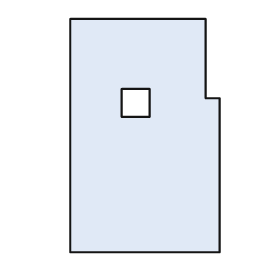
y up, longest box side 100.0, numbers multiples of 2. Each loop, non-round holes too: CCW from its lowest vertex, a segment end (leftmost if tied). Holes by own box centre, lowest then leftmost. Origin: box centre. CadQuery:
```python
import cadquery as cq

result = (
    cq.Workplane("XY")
    .moveTo(-32.0, -50.0)
    .lineTo(32.0, -50.0)
    .lineTo(32.0, 16.0)
    .lineTo(26.0, 16.0)
    .lineTo(26.0, 50.0)
    .lineTo(-32.0, 50.0)
    .close()
    .moveTo(-10.0, 8.0)
    .lineTo(2.0, 8.0)
    .lineTo(2.0, 20.0)
    .lineTo(-10.0, 20.0)
    .close()
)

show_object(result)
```